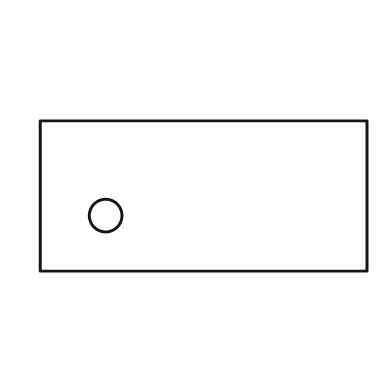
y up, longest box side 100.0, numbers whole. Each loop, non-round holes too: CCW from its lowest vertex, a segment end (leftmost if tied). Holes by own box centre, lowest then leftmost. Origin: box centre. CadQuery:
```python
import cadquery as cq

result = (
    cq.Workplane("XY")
    .moveTo(-50.0, -23.0)
    .lineTo(50.0, -23.0)
    .lineTo(50.0, 23.0)
    .lineTo(-50.0, 23.0)
    .close()
    .moveTo(-30.0, -6.0)
    .circle(5.0)
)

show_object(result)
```